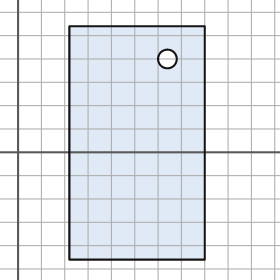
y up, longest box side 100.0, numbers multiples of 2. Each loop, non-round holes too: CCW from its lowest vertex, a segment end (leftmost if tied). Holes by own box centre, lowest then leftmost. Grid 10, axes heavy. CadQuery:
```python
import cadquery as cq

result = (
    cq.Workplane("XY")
    .moveTo(22.0, -46.0)
    .lineTo(80.0, -46.0)
    .lineTo(80.0, 54.0)
    .lineTo(22.0, 54.0)
    .close()
    .moveTo(64.0, 40.0)
    .circle(4.0)
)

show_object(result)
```